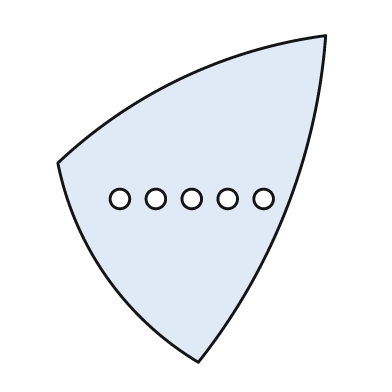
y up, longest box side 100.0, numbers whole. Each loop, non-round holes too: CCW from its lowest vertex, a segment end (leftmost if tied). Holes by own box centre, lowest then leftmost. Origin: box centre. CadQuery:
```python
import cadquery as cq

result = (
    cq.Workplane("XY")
    .moveTo(2.0, -50.0)
    .threePointArc((29.0, -3.0), (41.0, 50.0))
    .threePointArc((-3.0, 37.0), (-41.0, 11.0))
    .threePointArc((-26.0, -24.0), (2.0, -50.0))
    .close()
    .moveTo(-22.0, 0.0)
    .circle(3.0)
    .moveTo(-11.0, 0.0)
    .circle(3.0)
    .moveTo(0.0, 0.0)
    .circle(3.0)
    .moveTo(11.0, 0.0)
    .circle(3.0)
    .moveTo(22.0, 0.0)
    .circle(3.0)
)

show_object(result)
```